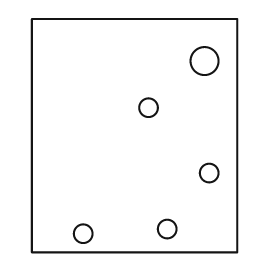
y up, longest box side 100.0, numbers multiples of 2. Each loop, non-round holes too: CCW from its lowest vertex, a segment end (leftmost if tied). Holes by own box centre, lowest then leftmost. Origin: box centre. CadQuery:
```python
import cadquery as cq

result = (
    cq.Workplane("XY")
    .moveTo(-44.0, -50.0)
    .lineTo(44.0, -50.0)
    .lineTo(44.0, 50.0)
    .lineTo(-44.0, 50.0)
    .close()
    .moveTo(-22.0, -42.0)
    .circle(4.0)
    .moveTo(14.0, -40.0)
    .circle(4.0)
    .moveTo(32.0, -16.0)
    .circle(4.0)
    .moveTo(6.0, 12.0)
    .circle(4.0)
    .moveTo(30.0, 32.0)
    .circle(6.0)
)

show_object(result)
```